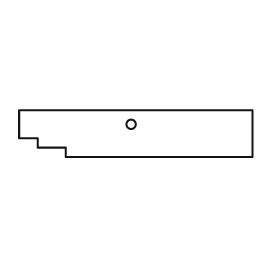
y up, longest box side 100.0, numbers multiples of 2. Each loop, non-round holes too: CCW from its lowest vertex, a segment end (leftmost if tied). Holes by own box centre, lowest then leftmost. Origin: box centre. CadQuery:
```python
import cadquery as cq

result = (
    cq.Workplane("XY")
    .moveTo(-30.0, -10.0)
    .lineTo(50.0, -10.0)
    .lineTo(50.0, 10.0)
    .lineTo(-50.0, 10.0)
    .lineTo(-50.0, -2.0)
    .lineTo(-42.0, -2.0)
    .lineTo(-42.0, -6.0)
    .lineTo(-30.0, -6.0)
    .close()
    .moveTo(-2.0, 4.0)
    .circle(2.0)
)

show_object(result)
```